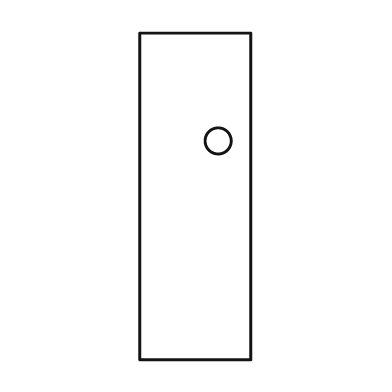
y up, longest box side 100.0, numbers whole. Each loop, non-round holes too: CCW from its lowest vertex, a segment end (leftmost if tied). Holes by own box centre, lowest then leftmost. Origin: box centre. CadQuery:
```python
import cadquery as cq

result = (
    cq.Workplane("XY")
    .moveTo(-17.0, -50.0)
    .lineTo(17.0, -50.0)
    .lineTo(17.0, 50.0)
    .lineTo(-17.0, 50.0)
    .close()
    .moveTo(7.0, 17.0)
    .circle(4.0)
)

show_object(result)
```